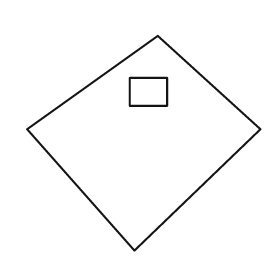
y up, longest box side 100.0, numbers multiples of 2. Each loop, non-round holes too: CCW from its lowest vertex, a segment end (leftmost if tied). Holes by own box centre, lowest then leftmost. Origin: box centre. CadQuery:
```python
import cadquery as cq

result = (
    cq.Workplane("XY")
    .moveTo(-4.0, -46.0)
    .lineTo(50.0, 6.0)
    .lineTo(6.0, 46.0)
    .lineTo(-50.0, 6.0)
    .close()
    .moveTo(-6.0, 16.0)
    .lineTo(10.0, 16.0)
    .lineTo(10.0, 28.0)
    .lineTo(-6.0, 28.0)
    .close()
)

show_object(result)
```